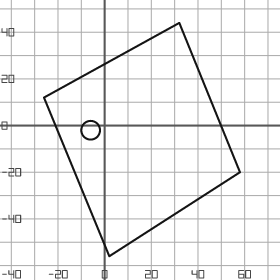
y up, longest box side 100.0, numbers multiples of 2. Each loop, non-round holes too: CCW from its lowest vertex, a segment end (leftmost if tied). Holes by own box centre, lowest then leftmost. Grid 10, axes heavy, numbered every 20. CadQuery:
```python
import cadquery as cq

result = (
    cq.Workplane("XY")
    .moveTo(2.0, -56.0)
    .lineTo(58.0, -20.0)
    .lineTo(32.0, 44.0)
    .lineTo(-26.0, 12.0)
    .close()
    .moveTo(-6.0, -2.0)
    .circle(4.0)
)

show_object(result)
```